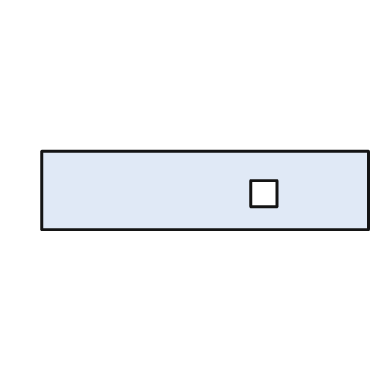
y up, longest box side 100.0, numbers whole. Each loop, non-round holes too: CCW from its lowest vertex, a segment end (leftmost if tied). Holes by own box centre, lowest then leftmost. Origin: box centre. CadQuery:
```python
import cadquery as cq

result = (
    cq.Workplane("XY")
    .moveTo(-50.0, -12.0)
    .lineTo(50.0, -12.0)
    .lineTo(50.0, 12.0)
    .lineTo(-50.0, 12.0)
    .close()
    .moveTo(14.0, -5.0)
    .lineTo(22.0, -5.0)
    .lineTo(22.0, 3.0)
    .lineTo(14.0, 3.0)
    .close()
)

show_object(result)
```